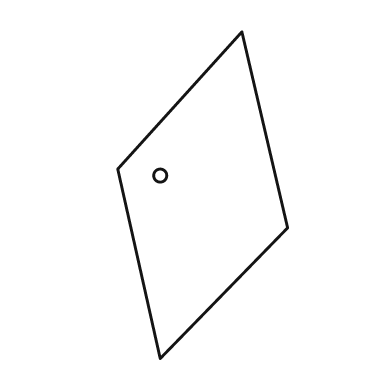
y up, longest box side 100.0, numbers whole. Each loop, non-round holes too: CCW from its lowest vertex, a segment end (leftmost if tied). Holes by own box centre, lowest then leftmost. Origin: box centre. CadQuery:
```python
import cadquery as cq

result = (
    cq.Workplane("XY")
    .moveTo(-13.0, -50.0)
    .lineTo(26.0, -10.0)
    .lineTo(12.0, 50.0)
    .lineTo(-26.0, 8.0)
    .close()
    .moveTo(-13.0, 6.0)
    .circle(2.0)
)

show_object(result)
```